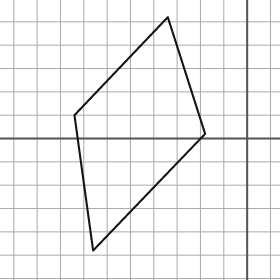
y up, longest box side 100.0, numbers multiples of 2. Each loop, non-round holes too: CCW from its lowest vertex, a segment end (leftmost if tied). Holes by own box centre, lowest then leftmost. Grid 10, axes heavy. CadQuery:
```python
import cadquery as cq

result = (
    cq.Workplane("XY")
    .moveTo(-66.0, -48.0)
    .lineTo(-18.0, 2.0)
    .lineTo(-34.0, 52.0)
    .lineTo(-74.0, 10.0)
    .close()
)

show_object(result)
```